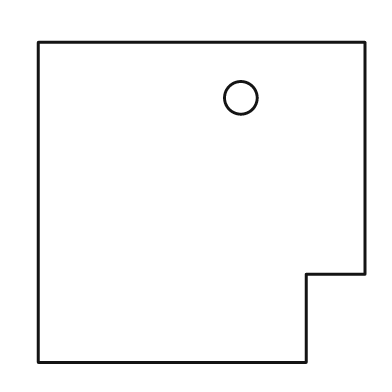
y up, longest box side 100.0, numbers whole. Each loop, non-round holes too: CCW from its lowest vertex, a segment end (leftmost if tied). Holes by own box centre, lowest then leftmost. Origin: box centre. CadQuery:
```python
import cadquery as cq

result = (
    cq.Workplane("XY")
    .moveTo(-50.0, -49.0)
    .lineTo(32.0, -49.0)
    .lineTo(32.0, -22.0)
    .lineTo(50.0, -22.0)
    .lineTo(50.0, 49.0)
    .lineTo(-50.0, 49.0)
    .close()
    .moveTo(12.0, 32.0)
    .circle(5.0)
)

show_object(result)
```